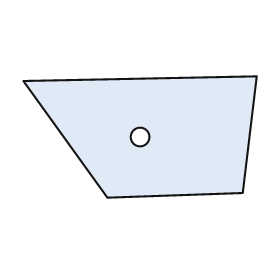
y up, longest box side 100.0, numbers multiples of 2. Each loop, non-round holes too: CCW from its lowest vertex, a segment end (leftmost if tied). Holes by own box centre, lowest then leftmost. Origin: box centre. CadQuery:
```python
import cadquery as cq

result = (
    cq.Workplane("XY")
    .moveTo(-14.0, -26.0)
    .lineTo(44.0, -24.0)
    .lineTo(50.0, 26.0)
    .lineTo(-50.0, 24.0)
    .close()
    .moveTo(0.0, 0.0)
    .circle(4.0)
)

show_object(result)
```